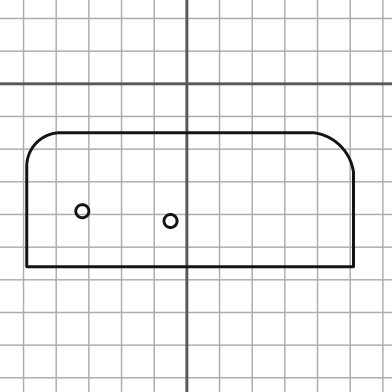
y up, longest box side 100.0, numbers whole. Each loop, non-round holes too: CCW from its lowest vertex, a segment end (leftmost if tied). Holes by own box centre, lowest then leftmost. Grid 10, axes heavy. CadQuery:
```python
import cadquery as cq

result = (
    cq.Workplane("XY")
    .moveTo(-49.0, -56.0)
    .lineTo(51.0, -56.0)
    .lineTo(51.0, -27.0)
    .threePointArc((47.0, -19.0), (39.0, -15.0))
    .lineTo(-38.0, -15.0)
    .threePointArc((-46.0, -18.0), (-49.0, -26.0))
    .close()
    .moveTo(-5.0, -42.0)
    .circle(2.0)
    .moveTo(-32.0, -39.0)
    .circle(2.0)
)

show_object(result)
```